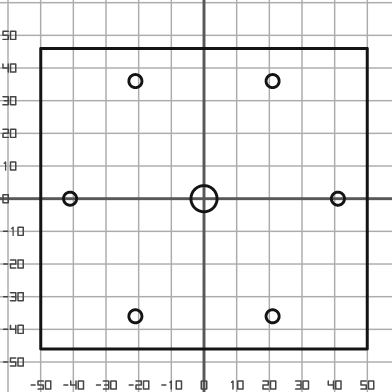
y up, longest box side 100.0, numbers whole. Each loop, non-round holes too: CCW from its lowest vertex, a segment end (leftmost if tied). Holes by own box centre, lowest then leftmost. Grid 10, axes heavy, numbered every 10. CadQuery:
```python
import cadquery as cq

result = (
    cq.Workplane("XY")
    .moveTo(-50.0, -46.0)
    .lineTo(50.0, -46.0)
    .lineTo(50.0, 46.0)
    .lineTo(-50.0, 46.0)
    .close()
    .moveTo(-21.0, -36.0)
    .circle(2.0)
    .moveTo(21.0, -36.0)
    .circle(2.0)
    .moveTo(-41.0, 0.0)
    .circle(2.0)
    .moveTo(0.0, 0.0)
    .circle(4.0)
    .moveTo(41.0, 0.0)
    .circle(2.0)
    .moveTo(-21.0, 36.0)
    .circle(2.0)
    .moveTo(21.0, 36.0)
    .circle(2.0)
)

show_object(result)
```